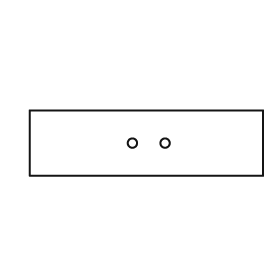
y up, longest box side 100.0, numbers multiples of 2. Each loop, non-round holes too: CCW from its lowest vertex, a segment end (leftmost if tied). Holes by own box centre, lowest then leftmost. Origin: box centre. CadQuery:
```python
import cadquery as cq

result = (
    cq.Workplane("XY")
    .moveTo(-50.0, -14.0)
    .lineTo(50.0, -14.0)
    .lineTo(50.0, 14.0)
    .lineTo(-50.0, 14.0)
    .close()
    .moveTo(-6.0, 0.0)
    .circle(2.0)
    .moveTo(8.0, 0.0)
    .circle(2.0)
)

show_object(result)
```